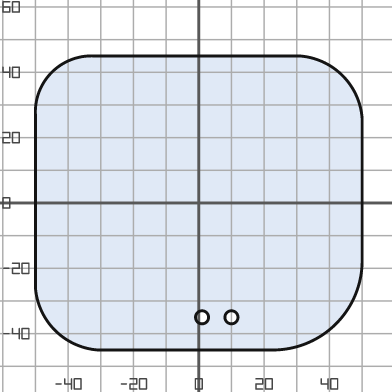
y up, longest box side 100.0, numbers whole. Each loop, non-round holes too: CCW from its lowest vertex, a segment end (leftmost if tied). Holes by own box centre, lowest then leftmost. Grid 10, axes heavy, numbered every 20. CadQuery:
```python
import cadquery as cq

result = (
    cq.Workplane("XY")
    .moveTo(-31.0, -45.0)
    .lineTo(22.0, -45.0)
    .threePointArc((42.0, -37.0), (50.0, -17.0))
    .lineTo(50.0, 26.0)
    .threePointArc((44.0, 39.0), (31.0, 45.0))
    .lineTo(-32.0, 45.0)
    .threePointArc((-45.0, 40.0), (-50.0, 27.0))
    .lineTo(-50.0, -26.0)
    .threePointArc((-44.0, -39.0), (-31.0, -45.0))
    .close()
    .moveTo(1.0, -35.0)
    .circle(2.0)
    .moveTo(10.0, -35.0)
    .circle(2.0)
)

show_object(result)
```